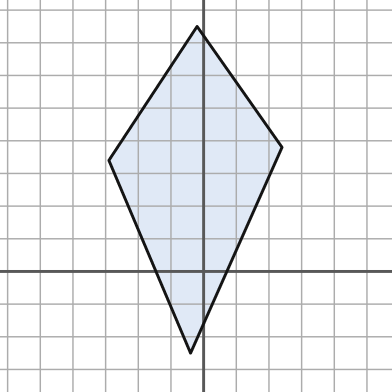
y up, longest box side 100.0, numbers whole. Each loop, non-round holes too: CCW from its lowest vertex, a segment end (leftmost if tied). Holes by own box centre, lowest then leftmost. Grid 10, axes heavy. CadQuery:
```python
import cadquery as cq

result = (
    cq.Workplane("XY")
    .moveTo(-4.0, -25.0)
    .lineTo(24.0, 38.0)
    .lineTo(-2.0, 75.0)
    .lineTo(-29.0, 34.0)
    .close()
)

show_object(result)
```